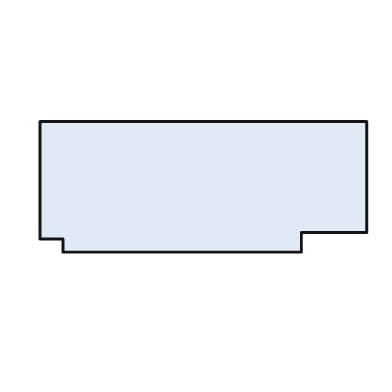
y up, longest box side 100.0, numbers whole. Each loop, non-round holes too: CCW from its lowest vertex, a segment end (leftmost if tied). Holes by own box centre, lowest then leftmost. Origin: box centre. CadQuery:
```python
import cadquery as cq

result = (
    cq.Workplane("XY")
    .moveTo(-43.0, -20.0)
    .lineTo(30.0, -20.0)
    .lineTo(30.0, -14.0)
    .lineTo(50.0, -14.0)
    .lineTo(50.0, 20.0)
    .lineTo(-50.0, 20.0)
    .lineTo(-50.0, -16.0)
    .lineTo(-43.0, -16.0)
    .close()
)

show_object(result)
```